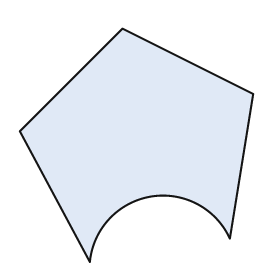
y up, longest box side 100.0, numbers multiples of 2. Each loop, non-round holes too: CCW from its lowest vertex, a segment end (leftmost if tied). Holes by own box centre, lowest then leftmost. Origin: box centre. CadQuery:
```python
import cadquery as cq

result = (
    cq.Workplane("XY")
    .moveTo(-20.0, -50.0)
    .threePointArc((6.0, -22.0), (40.0, -40.0))
    .lineTo(50.0, 22.0)
    .lineTo(-6.0, 50.0)
    .lineTo(-50.0, 6.0)
    .close()
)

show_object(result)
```